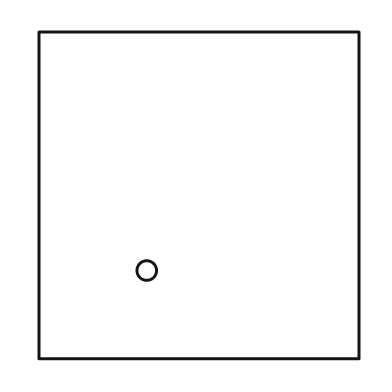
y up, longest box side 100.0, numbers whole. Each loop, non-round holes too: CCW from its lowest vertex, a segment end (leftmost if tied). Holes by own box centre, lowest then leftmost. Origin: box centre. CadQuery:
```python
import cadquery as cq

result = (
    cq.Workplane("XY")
    .moveTo(-49.0, -50.0)
    .lineTo(49.0, -50.0)
    .lineTo(49.0, 50.0)
    .lineTo(-49.0, 50.0)
    .close()
    .moveTo(-16.0, -23.0)
    .circle(3.0)
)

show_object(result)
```